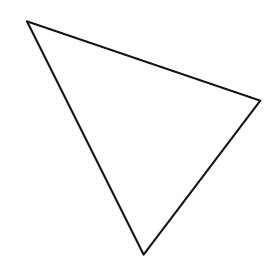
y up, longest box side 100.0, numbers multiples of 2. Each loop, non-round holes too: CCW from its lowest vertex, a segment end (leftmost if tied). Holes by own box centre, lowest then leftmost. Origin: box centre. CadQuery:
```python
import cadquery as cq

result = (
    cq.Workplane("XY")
    .moveTo(0.0, -50.0)
    .lineTo(50.0, 16.0)
    .lineTo(-50.0, 50.0)
    .close()
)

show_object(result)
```